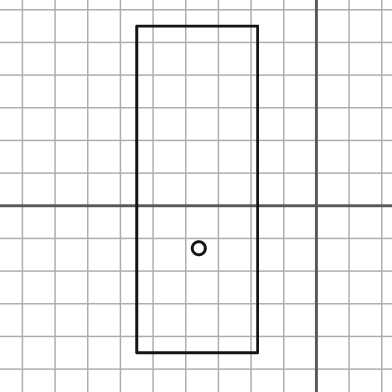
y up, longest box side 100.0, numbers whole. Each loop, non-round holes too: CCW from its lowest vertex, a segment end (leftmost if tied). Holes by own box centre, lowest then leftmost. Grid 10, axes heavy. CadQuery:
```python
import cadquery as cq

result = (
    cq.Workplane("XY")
    .moveTo(-55.0, -45.0)
    .lineTo(-18.0, -45.0)
    .lineTo(-18.0, 55.0)
    .lineTo(-55.0, 55.0)
    .close()
    .moveTo(-36.0, -13.0)
    .circle(2.0)
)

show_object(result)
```